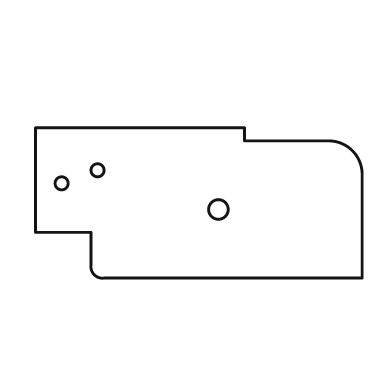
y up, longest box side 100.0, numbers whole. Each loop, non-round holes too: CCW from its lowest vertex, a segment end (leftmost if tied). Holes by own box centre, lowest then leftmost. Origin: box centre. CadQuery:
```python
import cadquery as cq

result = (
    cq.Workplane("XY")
    .moveTo(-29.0, -23.0)
    .lineTo(50.0, -23.0)
    .lineTo(50.0, 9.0)
    .threePointArc((47.0, 16.0), (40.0, 19.0))
    .lineTo(14.0, 19.0)
    .lineTo(14.0, 23.0)
    .lineTo(-50.0, 23.0)
    .lineTo(-50.0, -9.0)
    .lineTo(-33.0, -9.0)
    .lineTo(-33.0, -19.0)
    .threePointArc((-32.0, -22.0), (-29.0, -23.0))
    .close()
    .moveTo(6.0, -2.0)
    .circle(3.0)
    .moveTo(-42.0, 6.0)
    .circle(2.0)
    .moveTo(-31.0, 10.0)
    .circle(2.0)
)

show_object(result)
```